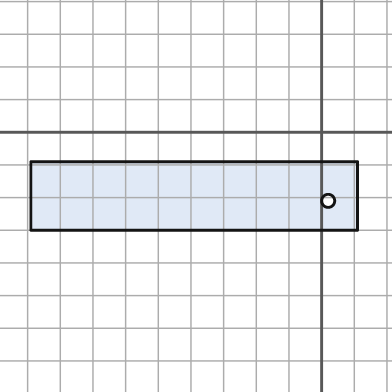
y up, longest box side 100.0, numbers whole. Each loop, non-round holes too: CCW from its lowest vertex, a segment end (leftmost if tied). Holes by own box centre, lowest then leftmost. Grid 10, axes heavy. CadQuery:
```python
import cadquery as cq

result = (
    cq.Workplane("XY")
    .moveTo(-89.0, -30.0)
    .lineTo(11.0, -30.0)
    .lineTo(11.0, -9.0)
    .lineTo(-89.0, -9.0)
    .close()
    .moveTo(2.0, -21.0)
    .circle(2.0)
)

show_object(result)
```